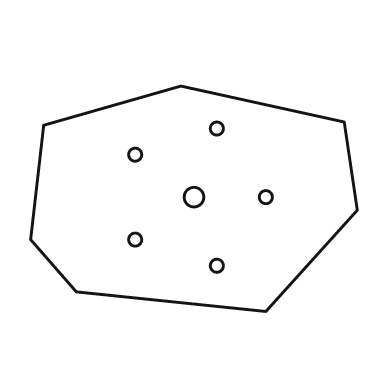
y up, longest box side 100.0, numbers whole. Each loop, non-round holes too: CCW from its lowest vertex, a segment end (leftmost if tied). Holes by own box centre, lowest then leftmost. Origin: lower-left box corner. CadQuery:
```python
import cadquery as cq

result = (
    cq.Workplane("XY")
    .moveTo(72.0, 0.0)
    .lineTo(100.0, 31.0)
    .lineTo(96.0, 58.0)
    .lineTo(46.0, 69.0)
    .lineTo(4.0, 57.0)
    .lineTo(0.0, 22.0)
    .lineTo(14.0, 6.0)
    .close()
    .moveTo(57.0, 14.0)
    .circle(2.0)
    .moveTo(32.0, 22.0)
    .circle(2.0)
    .moveTo(50.0, 35.0)
    .circle(3.0)
    .moveTo(72.0, 35.0)
    .circle(2.0)
    .moveTo(32.0, 48.0)
    .circle(2.0)
    .moveTo(57.0, 56.0)
    .circle(2.0)
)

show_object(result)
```